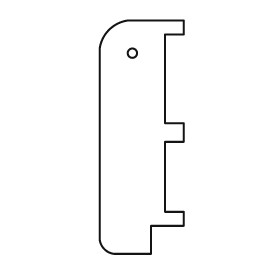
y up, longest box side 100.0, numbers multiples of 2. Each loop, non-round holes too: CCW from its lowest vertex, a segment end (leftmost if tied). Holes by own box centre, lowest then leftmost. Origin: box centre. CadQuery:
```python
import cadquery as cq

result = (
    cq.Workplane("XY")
    .moveTo(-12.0, -50.0)
    .lineTo(4.0, -50.0)
    .lineTo(4.0, -38.0)
    .lineTo(18.0, -38.0)
    .lineTo(18.0, -32.0)
    .lineTo(10.0, -32.0)
    .lineTo(10.0, -2.0)
    .lineTo(18.0, -2.0)
    .lineTo(18.0, 6.0)
    .lineTo(10.0, 6.0)
    .lineTo(10.0, 44.0)
    .lineTo(18.0, 44.0)
    .lineTo(18.0, 50.0)
    .lineTo(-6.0, 50.0)
    .threePointArc((-14.0, 46.0), (-18.0, 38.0))
    .lineTo(-18.0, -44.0)
    .threePointArc((-16.0, -48.0), (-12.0, -50.0))
    .close()
    .moveTo(-4.0, 36.0)
    .circle(2.0)
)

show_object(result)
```